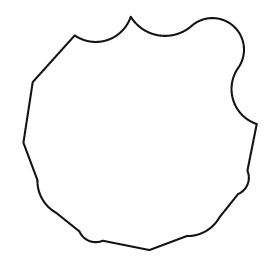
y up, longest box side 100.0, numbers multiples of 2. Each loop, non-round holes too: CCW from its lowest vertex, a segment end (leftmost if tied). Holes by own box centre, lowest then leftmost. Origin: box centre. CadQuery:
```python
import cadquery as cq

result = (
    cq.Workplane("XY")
    .moveTo(4.0, -50.0)
    .lineTo(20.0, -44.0)
    .threePointArc((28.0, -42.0), (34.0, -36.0))
    .lineTo(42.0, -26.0)
    .threePointArc((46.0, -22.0), (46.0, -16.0))
    .lineTo(50.0, 4.0)
    .threePointArc((40.0, 14.0), (42.0, 28.0))
    .threePointArc((40.0, 46.0), (22.0, 46.0))
    .threePointArc((8.0, 42.0), (-4.0, 50.0))
    .threePointArc((-14.0, 40.0), (-28.0, 42.0))
    .lineTo(-46.0, 22.0)
    .lineTo(-50.0, -4.0)
    .lineTo(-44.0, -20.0)
    .threePointArc((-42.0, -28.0), (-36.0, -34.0))
    .lineTo(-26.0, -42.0)
    .threePointArc((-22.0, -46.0), (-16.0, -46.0))
    .close()
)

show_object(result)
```